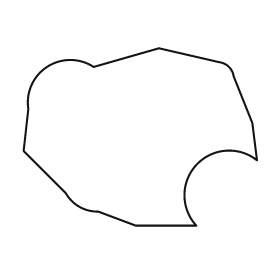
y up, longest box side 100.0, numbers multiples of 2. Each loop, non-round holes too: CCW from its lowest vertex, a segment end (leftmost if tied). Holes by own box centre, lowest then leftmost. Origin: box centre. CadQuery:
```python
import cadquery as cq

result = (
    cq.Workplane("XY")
    .moveTo(-2.0, -38.0)
    .lineTo(24.0, -38.0)
    .threePointArc((24.0, -12.0), (50.0, -10.0))
    .lineTo(48.0, 6.0)
    .lineTo(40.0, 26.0)
    .threePointArc((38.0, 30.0), (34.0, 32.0))
    .lineTo(8.0, 38.0)
    .lineTo(-20.0, 30.0)
    .threePointArc((-40.0, 30.0), (-48.0, 12.0))
    .lineTo(-50.0, -6.0)
    .lineTo(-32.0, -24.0)
    .threePointArc((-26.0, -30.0), (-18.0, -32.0))
    .close()
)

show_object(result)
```